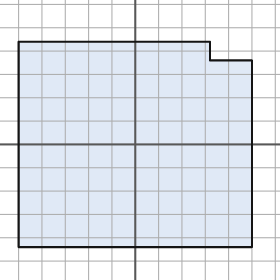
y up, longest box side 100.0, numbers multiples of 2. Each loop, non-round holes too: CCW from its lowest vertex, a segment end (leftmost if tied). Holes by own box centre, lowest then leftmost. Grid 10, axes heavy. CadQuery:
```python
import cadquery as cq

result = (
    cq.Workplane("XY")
    .moveTo(-50.0, -44.0)
    .lineTo(50.0, -44.0)
    .lineTo(50.0, 36.0)
    .lineTo(32.0, 36.0)
    .lineTo(32.0, 44.0)
    .lineTo(-50.0, 44.0)
    .close()
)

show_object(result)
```